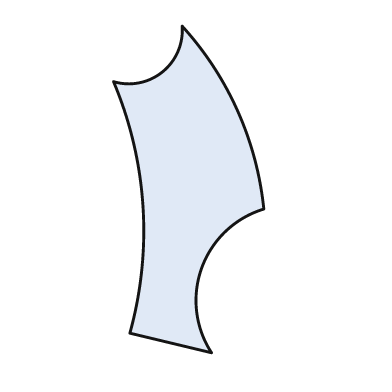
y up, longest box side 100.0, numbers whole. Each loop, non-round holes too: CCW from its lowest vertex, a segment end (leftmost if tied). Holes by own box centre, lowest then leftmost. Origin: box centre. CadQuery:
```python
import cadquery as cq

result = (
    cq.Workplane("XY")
    .moveTo(7.0, -50.0)
    .threePointArc((4.0, -24.0), (23.0, -6.0))
    .threePointArc((15.0, 24.0), (-2.0, 50.0))
    .threePointArc((-8.0, 36.0), (-23.0, 33.0))
    .threePointArc((-14.0, -5.0), (-18.0, -44.0))
    .close()
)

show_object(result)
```